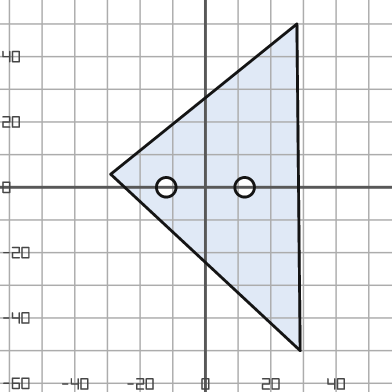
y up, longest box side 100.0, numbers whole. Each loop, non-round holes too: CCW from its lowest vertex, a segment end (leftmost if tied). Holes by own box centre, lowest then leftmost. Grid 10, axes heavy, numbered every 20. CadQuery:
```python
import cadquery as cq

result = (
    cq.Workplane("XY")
    .moveTo(29.0, -50.0)
    .lineTo(28.0, 50.0)
    .lineTo(-29.0, 4.0)
    .close()
    .moveTo(-12.0, 0.0)
    .circle(3.0)
    .moveTo(12.0, 0.0)
    .circle(3.0)
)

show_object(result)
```